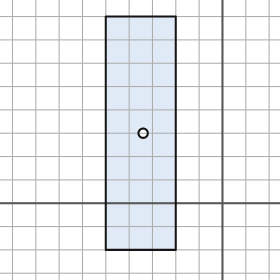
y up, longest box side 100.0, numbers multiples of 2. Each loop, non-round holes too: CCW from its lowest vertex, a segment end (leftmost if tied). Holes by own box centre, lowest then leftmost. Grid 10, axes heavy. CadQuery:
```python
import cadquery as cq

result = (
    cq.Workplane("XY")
    .moveTo(-50.0, -20.0)
    .lineTo(-20.0, -20.0)
    .lineTo(-20.0, 80.0)
    .lineTo(-50.0, 80.0)
    .close()
    .moveTo(-34.0, 30.0)
    .circle(2.0)
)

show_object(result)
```